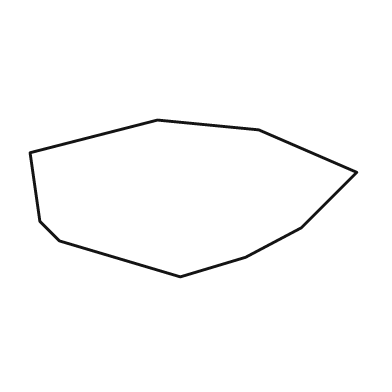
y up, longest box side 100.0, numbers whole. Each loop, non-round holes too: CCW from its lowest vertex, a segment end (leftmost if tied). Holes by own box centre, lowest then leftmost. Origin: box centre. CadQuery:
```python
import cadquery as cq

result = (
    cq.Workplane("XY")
    .moveTo(-4.0, -24.0)
    .lineTo(16.0, -18.0)
    .lineTo(33.0, -9.0)
    .lineTo(50.0, 8.0)
    .lineTo(20.0, 21.0)
    .lineTo(-11.0, 24.0)
    .lineTo(-50.0, 14.0)
    .lineTo(-47.0, -7.0)
    .lineTo(-41.0, -13.0)
    .close()
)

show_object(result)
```